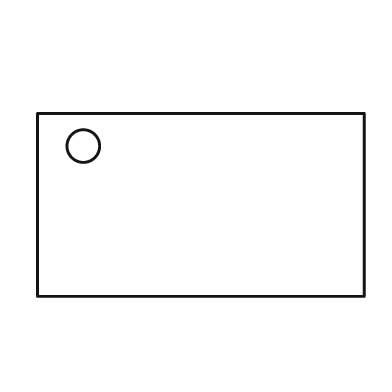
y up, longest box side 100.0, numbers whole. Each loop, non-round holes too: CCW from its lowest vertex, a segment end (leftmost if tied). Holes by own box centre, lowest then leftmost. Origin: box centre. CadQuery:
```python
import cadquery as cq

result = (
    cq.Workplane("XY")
    .moveTo(-50.0, -28.0)
    .lineTo(50.0, -28.0)
    .lineTo(50.0, 28.0)
    .lineTo(-50.0, 28.0)
    .close()
    .moveTo(-36.0, 18.0)
    .circle(5.0)
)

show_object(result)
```